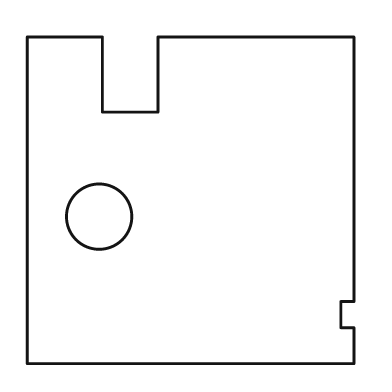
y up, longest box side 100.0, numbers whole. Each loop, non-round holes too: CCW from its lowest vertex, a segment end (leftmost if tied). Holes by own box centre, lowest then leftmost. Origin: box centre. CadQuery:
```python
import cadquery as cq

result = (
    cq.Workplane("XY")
    .moveTo(-50.0, -50.0)
    .lineTo(50.0, -50.0)
    .lineTo(50.0, -39.0)
    .lineTo(46.0, -39.0)
    .lineTo(46.0, -31.0)
    .lineTo(50.0, -31.0)
    .lineTo(50.0, 50.0)
    .lineTo(-10.0, 50.0)
    .lineTo(-10.0, 27.0)
    .lineTo(-27.0, 27.0)
    .lineTo(-27.0, 50.0)
    .lineTo(-50.0, 50.0)
    .close()
    .moveTo(-28.0, -5.0)
    .circle(10.0)
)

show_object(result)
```